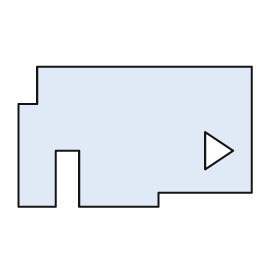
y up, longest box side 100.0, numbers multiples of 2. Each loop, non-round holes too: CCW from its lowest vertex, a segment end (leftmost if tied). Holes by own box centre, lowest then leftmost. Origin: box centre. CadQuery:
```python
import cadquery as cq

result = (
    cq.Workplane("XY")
    .moveTo(-50.0, -30.0)
    .lineTo(-34.0, -30.0)
    .lineTo(-34.0, -6.0)
    .lineTo(-24.0, -6.0)
    .lineTo(-24.0, -30.0)
    .lineTo(10.0, -30.0)
    .lineTo(10.0, -24.0)
    .lineTo(50.0, -24.0)
    .lineTo(50.0, 30.0)
    .lineTo(-42.0, 30.0)
    .lineTo(-42.0, 14.0)
    .lineTo(-50.0, 14.0)
    .close()
    .moveTo(30.0, -14.0)
    .lineTo(42.0, -6.0)
    .lineTo(30.0, 2.0)
    .close()
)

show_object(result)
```